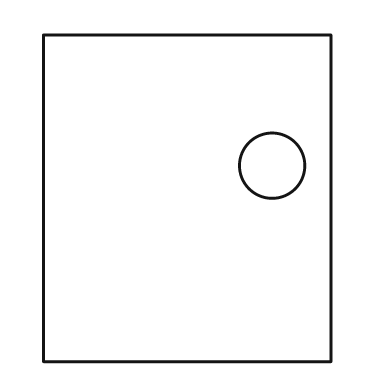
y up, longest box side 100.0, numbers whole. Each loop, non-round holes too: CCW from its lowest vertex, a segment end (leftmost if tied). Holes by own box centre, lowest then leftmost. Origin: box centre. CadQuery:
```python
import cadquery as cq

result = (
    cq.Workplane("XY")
    .moveTo(-44.0, -50.0)
    .lineTo(44.0, -50.0)
    .lineTo(44.0, 50.0)
    .lineTo(-44.0, 50.0)
    .close()
    .moveTo(26.0, 10.0)
    .circle(10.0)
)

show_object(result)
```